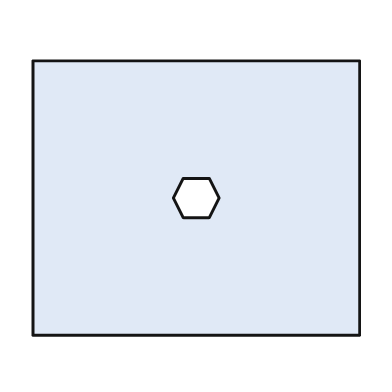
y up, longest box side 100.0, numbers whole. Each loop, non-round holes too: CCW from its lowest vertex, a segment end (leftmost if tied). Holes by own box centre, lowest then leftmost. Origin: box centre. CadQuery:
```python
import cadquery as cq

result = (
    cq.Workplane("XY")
    .moveTo(-50.0, -42.0)
    .lineTo(50.0, -42.0)
    .lineTo(50.0, 42.0)
    .lineTo(-50.0, 42.0)
    .close()
    .moveTo(-4.0, -6.0)
    .lineTo(4.0, -6.0)
    .lineTo(7.0, 0.0)
    .lineTo(4.0, 6.0)
    .lineTo(-4.0, 6.0)
    .lineTo(-7.0, 0.0)
    .close()
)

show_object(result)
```